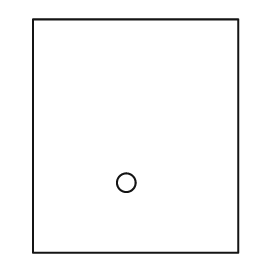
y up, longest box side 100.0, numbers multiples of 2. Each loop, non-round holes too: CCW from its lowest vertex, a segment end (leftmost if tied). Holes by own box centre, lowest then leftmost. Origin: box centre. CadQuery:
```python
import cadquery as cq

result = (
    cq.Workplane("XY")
    .moveTo(-44.0, -50.0)
    .lineTo(44.0, -50.0)
    .lineTo(44.0, 50.0)
    .lineTo(-44.0, 50.0)
    .close()
    .moveTo(-4.0, -20.0)
    .circle(4.0)
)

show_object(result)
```